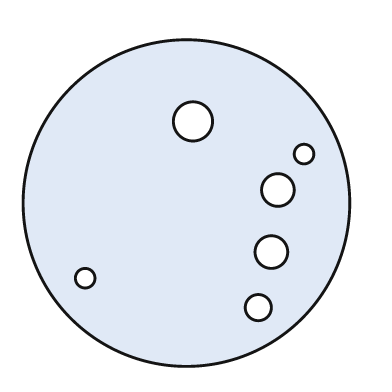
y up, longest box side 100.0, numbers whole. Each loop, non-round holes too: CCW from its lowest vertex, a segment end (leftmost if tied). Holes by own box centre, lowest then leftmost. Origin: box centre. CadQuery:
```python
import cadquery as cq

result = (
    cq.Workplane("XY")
    .moveTo(0.0, 0.0)
    .circle(50.0)
    .moveTo(22.0, -32.0)
    .circle(4.0)
    .moveTo(-31.0, -23.0)
    .circle(3.0)
    .moveTo(26.0, -15.0)
    .circle(5.0)
    .moveTo(28.0, 4.0)
    .circle(5.0)
    .moveTo(36.0, 15.0)
    .circle(3.0)
    .moveTo(2.0, 25.0)
    .circle(6.0)
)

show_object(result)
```